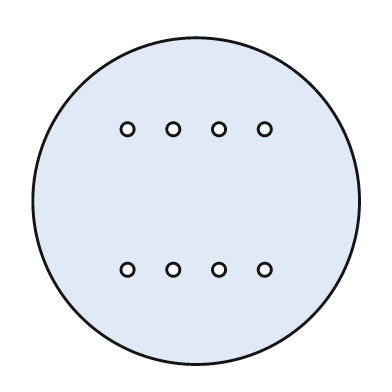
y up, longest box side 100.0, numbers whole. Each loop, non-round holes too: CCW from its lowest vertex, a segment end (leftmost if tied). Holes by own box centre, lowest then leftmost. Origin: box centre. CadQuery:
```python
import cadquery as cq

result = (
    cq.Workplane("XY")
    .moveTo(0.0, 0.0)
    .circle(50.0)
    .moveTo(-21.0, -21.0)
    .circle(2.0)
    .moveTo(-7.0, -21.0)
    .circle(2.0)
    .moveTo(7.0, -21.0)
    .circle(2.0)
    .moveTo(21.0, -21.0)
    .circle(2.0)
    .moveTo(-21.0, 22.0)
    .circle(2.0)
    .moveTo(-7.0, 22.0)
    .circle(2.0)
    .moveTo(7.0, 22.0)
    .circle(2.0)
    .moveTo(21.0, 22.0)
    .circle(2.0)
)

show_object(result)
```